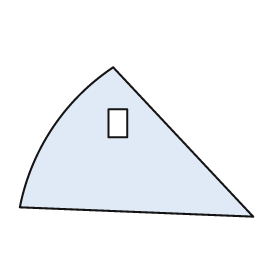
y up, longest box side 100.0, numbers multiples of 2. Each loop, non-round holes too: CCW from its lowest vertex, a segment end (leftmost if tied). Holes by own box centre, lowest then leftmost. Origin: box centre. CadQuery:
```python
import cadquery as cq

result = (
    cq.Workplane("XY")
    .moveTo(50.0, -32.0)
    .lineTo(-10.0, 32.0)
    .threePointArc((-36.0, 6.0), (-50.0, -28.0))
    .close()
    .moveTo(-12.0, 2.0)
    .lineTo(-4.0, 2.0)
    .lineTo(-4.0, 14.0)
    .lineTo(-12.0, 14.0)
    .close()
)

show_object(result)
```